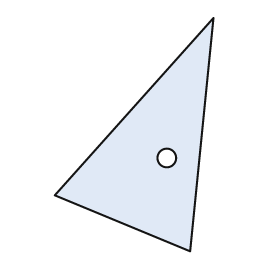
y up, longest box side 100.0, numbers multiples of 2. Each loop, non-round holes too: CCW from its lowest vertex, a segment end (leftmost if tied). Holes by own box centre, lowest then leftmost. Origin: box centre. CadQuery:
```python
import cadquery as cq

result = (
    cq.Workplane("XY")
    .moveTo(24.0, -50.0)
    .lineTo(34.0, 50.0)
    .lineTo(-34.0, -26.0)
    .close()
    .moveTo(14.0, -10.0)
    .circle(4.0)
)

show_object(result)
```